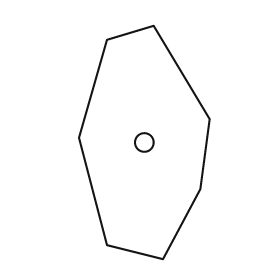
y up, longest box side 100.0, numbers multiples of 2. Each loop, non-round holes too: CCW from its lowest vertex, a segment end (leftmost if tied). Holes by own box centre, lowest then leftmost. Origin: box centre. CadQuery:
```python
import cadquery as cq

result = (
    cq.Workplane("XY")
    .moveTo(8.0, -50.0)
    .lineTo(24.0, -20.0)
    .lineTo(28.0, 10.0)
    .lineTo(4.0, 50.0)
    .lineTo(-16.0, 44.0)
    .lineTo(-28.0, 2.0)
    .lineTo(-16.0, -44.0)
    .close()
    .moveTo(0.0, 0.0)
    .circle(4.0)
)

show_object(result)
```